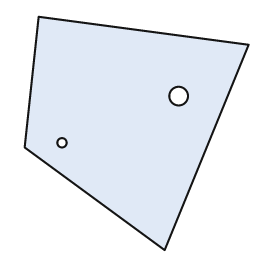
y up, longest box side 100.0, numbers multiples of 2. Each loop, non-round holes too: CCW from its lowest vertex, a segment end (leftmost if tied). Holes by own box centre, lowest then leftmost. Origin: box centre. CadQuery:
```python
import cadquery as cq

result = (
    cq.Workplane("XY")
    .moveTo(12.0, -50.0)
    .lineTo(48.0, 38.0)
    .lineTo(-42.0, 50.0)
    .lineTo(-48.0, -6.0)
    .close()
    .moveTo(-32.0, -4.0)
    .circle(2.0)
    .moveTo(18.0, 16.0)
    .circle(4.0)
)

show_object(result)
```